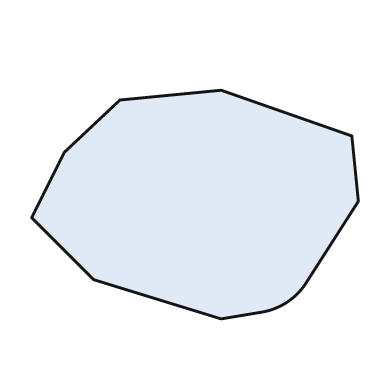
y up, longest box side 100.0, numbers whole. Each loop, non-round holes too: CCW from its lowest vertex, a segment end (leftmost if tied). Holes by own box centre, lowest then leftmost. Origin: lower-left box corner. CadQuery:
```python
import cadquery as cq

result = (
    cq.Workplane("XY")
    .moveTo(58.0, 0.0)
    .lineTo(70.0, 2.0)
    .threePointArc((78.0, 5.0), (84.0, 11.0))
    .lineTo(100.0, 36.0)
    .lineTo(98.0, 56.0)
    .lineTo(58.0, 70.0)
    .lineTo(27.0, 67.0)
    .lineTo(10.0, 51.0)
    .lineTo(0.0, 31.0)
    .lineTo(19.0, 12.0)
    .close()
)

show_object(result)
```